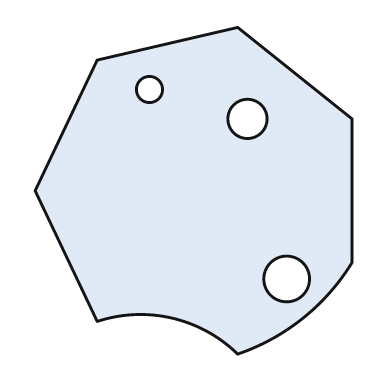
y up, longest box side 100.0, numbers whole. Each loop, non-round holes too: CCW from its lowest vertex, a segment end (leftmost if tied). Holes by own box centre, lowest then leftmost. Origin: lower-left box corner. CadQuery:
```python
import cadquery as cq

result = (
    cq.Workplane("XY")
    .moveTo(62.0, 0.0)
    .threePointArc((82.0, 11.0), (97.0, 28.0))
    .lineTo(97.0, 72.0)
    .lineTo(62.0, 100.0)
    .lineTo(19.0, 90.0)
    .lineTo(0.0, 50.0)
    .lineTo(19.0, 10.0)
    .threePointArc((42.0, 11.0), (62.0, 0.0))
    .close()
    .moveTo(77.0, 23.0)
    .circle(7.0)
    .moveTo(65.0, 72.0)
    .circle(6.0)
    .moveTo(35.0, 81.0)
    .circle(4.0)
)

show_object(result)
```